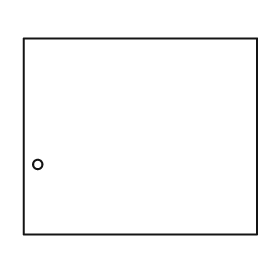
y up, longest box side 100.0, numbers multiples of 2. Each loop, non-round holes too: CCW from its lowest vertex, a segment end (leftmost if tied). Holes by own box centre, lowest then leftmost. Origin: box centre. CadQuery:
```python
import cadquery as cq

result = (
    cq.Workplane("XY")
    .moveTo(-50.0, -42.0)
    .lineTo(50.0, -42.0)
    .lineTo(50.0, 42.0)
    .lineTo(-50.0, 42.0)
    .close()
    .moveTo(-44.0, -12.0)
    .circle(2.0)
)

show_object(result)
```